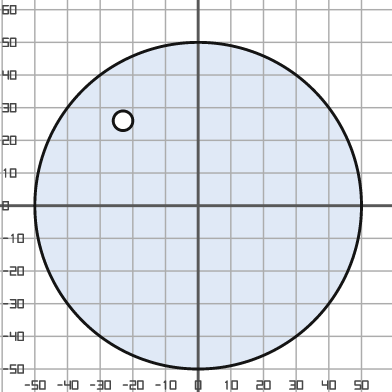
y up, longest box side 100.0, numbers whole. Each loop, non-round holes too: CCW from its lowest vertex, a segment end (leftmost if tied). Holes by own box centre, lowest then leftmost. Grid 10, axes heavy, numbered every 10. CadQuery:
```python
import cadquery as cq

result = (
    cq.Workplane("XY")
    .moveTo(0.0, 0.0)
    .circle(50.0)
    .moveTo(-23.0, 26.0)
    .circle(3.0)
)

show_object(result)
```